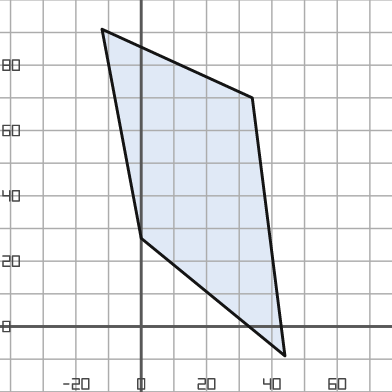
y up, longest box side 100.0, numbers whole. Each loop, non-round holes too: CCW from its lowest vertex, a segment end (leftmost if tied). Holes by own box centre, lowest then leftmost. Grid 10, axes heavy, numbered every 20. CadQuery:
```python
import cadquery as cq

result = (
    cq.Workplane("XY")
    .moveTo(44.0, -9.0)
    .lineTo(34.0, 70.0)
    .lineTo(-12.0, 91.0)
    .lineTo(0.0, 27.0)
    .close()
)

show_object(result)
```